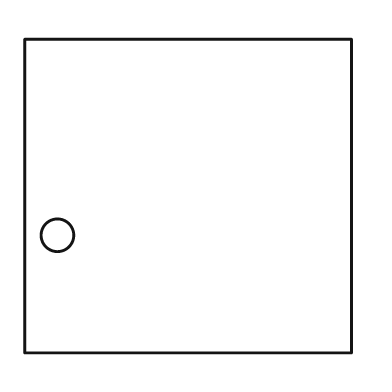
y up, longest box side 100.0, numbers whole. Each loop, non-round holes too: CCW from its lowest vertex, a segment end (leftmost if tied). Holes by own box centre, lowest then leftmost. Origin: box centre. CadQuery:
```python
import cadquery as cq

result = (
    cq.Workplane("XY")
    .moveTo(-50.0, -48.0)
    .lineTo(50.0, -48.0)
    .lineTo(50.0, 48.0)
    .lineTo(-50.0, 48.0)
    .close()
    .moveTo(-40.0, -12.0)
    .circle(5.0)
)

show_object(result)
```